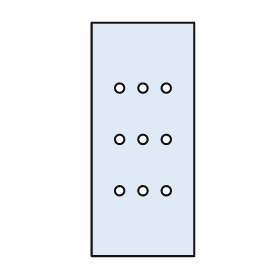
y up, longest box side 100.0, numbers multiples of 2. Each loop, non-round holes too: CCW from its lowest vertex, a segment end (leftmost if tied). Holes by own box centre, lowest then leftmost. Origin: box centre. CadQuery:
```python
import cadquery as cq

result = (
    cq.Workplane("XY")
    .moveTo(-22.0, -50.0)
    .lineTo(22.0, -50.0)
    .lineTo(22.0, 50.0)
    .lineTo(-22.0, 50.0)
    .close()
    .moveTo(-10.0, -22.0)
    .circle(2.0)
    .moveTo(0.0, -22.0)
    .circle(2.0)
    .moveTo(10.0, -22.0)
    .circle(2.0)
    .moveTo(-10.0, 0.0)
    .circle(2.0)
    .moveTo(0.0, 0.0)
    .circle(2.0)
    .moveTo(10.0, 0.0)
    .circle(2.0)
    .moveTo(-10.0, 22.0)
    .circle(2.0)
    .moveTo(0.0, 22.0)
    .circle(2.0)
    .moveTo(10.0, 22.0)
    .circle(2.0)
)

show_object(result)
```